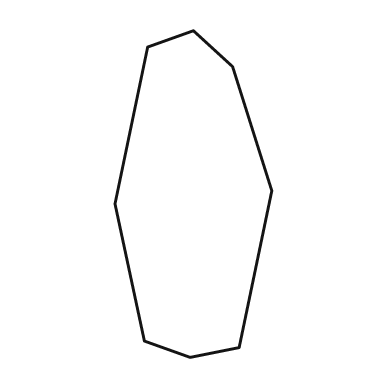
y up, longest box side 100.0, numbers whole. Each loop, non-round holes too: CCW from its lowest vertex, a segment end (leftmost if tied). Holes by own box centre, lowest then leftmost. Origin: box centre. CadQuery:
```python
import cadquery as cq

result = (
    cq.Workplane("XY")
    .moveTo(-1.0, -50.0)
    .lineTo(14.0, -47.0)
    .lineTo(24.0, 1.0)
    .lineTo(12.0, 39.0)
    .lineTo(0.0, 50.0)
    .lineTo(-14.0, 45.0)
    .lineTo(-24.0, -3.0)
    .lineTo(-15.0, -45.0)
    .close()
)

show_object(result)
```